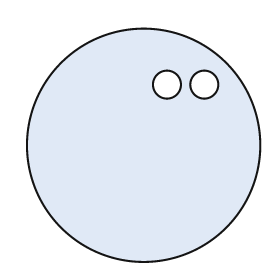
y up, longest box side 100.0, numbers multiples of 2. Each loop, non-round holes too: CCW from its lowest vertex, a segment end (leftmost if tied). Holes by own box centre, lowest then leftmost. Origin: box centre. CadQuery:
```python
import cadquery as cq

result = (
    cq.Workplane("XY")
    .moveTo(0.0, 0.0)
    .circle(50.0)
    .moveTo(10.0, 26.0)
    .circle(6.0)
    .moveTo(26.0, 26.0)
    .circle(6.0)
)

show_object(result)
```